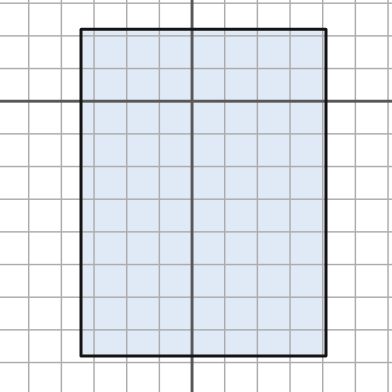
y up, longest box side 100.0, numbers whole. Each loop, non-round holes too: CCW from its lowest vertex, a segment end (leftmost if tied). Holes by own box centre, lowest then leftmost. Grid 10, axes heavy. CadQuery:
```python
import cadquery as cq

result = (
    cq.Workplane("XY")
    .moveTo(-34.0, -78.0)
    .lineTo(41.0, -78.0)
    .lineTo(41.0, 22.0)
    .lineTo(-34.0, 22.0)
    .close()
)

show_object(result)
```